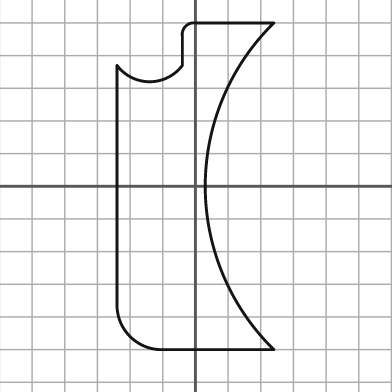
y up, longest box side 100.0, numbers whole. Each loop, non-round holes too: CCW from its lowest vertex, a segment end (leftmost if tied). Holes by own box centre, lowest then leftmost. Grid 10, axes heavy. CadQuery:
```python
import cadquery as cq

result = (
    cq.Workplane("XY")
    .moveTo(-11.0, -50.0)
    .lineTo(24.0, -50.0)
    .threePointArc((3.0, 0.0), (24.0, 50.0))
    .lineTo(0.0, 50.0)
    .threePointArc((-3.0, 49.0), (-4.0, 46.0))
    .lineTo(-4.0, 37.0)
    .threePointArc((-14.0, 32.0), (-24.0, 37.0))
    .lineTo(-24.0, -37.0)
    .threePointArc((-20.0, -46.0), (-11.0, -50.0))
    .close()
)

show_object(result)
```